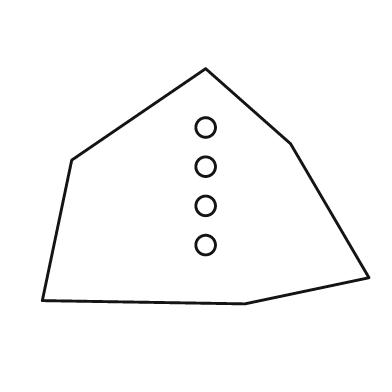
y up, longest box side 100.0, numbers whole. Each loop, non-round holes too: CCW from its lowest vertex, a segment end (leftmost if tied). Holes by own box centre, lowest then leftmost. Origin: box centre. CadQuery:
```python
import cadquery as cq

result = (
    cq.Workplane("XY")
    .moveTo(12.0, -36.0)
    .lineTo(50.0, -28.0)
    .lineTo(26.0, 13.0)
    .lineTo(0.0, 36.0)
    .lineTo(-41.0, 8.0)
    .lineTo(-50.0, -35.0)
    .close()
    .moveTo(0.0, -18.0)
    .circle(3.0)
    .moveTo(0.0, -6.0)
    .circle(3.0)
    .moveTo(0.0, 6.0)
    .circle(3.0)
    .moveTo(0.0, 18.0)
    .circle(3.0)
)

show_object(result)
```